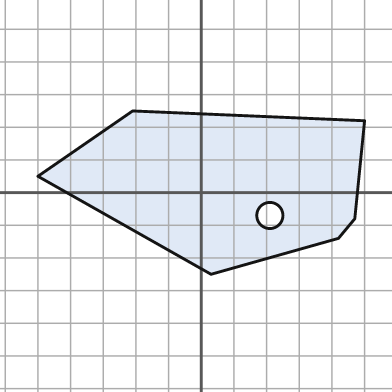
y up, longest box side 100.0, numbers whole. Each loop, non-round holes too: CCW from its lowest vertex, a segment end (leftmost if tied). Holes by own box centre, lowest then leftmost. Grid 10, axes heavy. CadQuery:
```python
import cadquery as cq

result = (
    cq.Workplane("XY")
    .moveTo(3.0, -25.0)
    .lineTo(42.0, -14.0)
    .lineTo(47.0, -8.0)
    .lineTo(50.0, 22.0)
    .lineTo(-21.0, 25.0)
    .lineTo(-50.0, 5.0)
    .close()
    .moveTo(21.0, -7.0)
    .circle(4.0)
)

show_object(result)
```